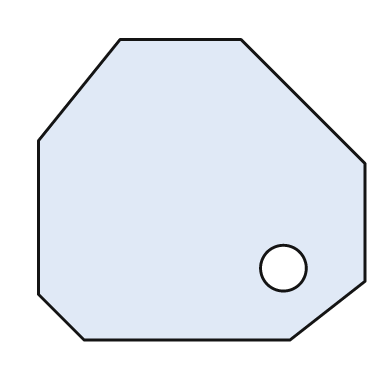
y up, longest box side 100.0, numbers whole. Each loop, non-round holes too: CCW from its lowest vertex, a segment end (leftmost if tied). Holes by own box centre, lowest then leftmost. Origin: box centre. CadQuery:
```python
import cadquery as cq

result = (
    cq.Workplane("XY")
    .moveTo(-36.0, -46.0)
    .lineTo(27.0, -46.0)
    .lineTo(50.0, -28.0)
    .lineTo(50.0, 8.0)
    .lineTo(12.0, 46.0)
    .lineTo(-25.0, 46.0)
    .lineTo(-50.0, 15.0)
    .lineTo(-50.0, -32.0)
    .close()
    .moveTo(25.0, -24.0)
    .circle(7.0)
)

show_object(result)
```